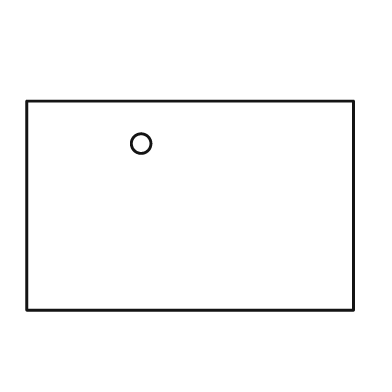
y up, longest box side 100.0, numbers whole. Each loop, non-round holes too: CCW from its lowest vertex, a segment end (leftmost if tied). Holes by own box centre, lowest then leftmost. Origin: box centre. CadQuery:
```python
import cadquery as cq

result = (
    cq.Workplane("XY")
    .moveTo(-50.0, -32.0)
    .lineTo(50.0, -32.0)
    .lineTo(50.0, 32.0)
    .lineTo(-50.0, 32.0)
    .close()
    .moveTo(-15.0, 19.0)
    .circle(3.0)
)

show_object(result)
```